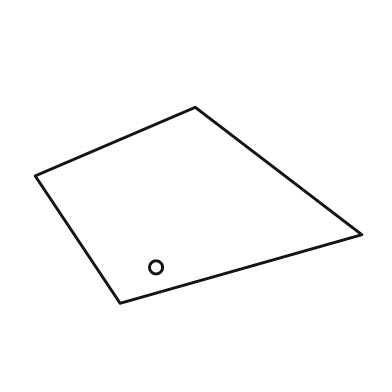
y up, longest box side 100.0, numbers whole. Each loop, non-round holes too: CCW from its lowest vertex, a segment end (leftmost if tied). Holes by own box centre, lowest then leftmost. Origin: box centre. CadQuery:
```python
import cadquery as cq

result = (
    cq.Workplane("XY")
    .moveTo(-24.0, -30.0)
    .lineTo(50.0, -9.0)
    .lineTo(-1.0, 30.0)
    .lineTo(-50.0, 9.0)
    .close()
    .moveTo(-13.0, -19.0)
    .circle(2.0)
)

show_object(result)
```